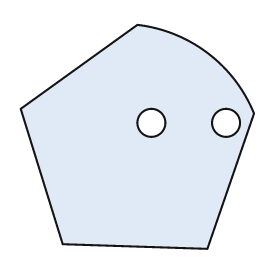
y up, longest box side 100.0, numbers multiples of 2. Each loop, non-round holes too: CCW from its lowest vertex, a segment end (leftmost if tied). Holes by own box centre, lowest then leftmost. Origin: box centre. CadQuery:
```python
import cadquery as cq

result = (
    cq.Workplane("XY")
    .moveTo(30.0, -48.0)
    .lineTo(50.0, 10.0)
    .threePointArc((30.0, 36.0), (0.0, 48.0))
    .lineTo(-50.0, 12.0)
    .lineTo(-32.0, -46.0)
    .close()
    .moveTo(6.0, 6.0)
    .circle(6.0)
    .moveTo(38.0, 6.0)
    .circle(6.0)
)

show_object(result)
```